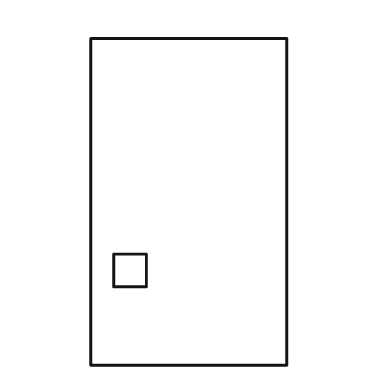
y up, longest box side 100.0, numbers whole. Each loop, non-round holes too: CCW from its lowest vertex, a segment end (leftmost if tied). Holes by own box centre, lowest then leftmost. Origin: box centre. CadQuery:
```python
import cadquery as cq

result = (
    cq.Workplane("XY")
    .moveTo(-30.0, -50.0)
    .lineTo(30.0, -50.0)
    .lineTo(30.0, 50.0)
    .lineTo(-30.0, 50.0)
    .close()
    .moveTo(-23.0, -26.0)
    .lineTo(-13.0, -26.0)
    .lineTo(-13.0, -16.0)
    .lineTo(-23.0, -16.0)
    .close()
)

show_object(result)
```